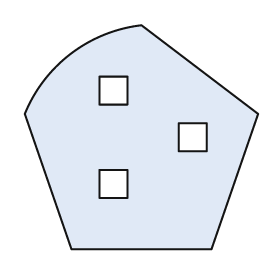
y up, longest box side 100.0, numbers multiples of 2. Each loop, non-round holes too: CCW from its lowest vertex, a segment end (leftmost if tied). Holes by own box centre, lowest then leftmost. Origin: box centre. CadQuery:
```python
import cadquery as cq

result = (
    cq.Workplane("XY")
    .moveTo(-30.0, -48.0)
    .lineTo(30.0, -48.0)
    .lineTo(50.0, 10.0)
    .lineTo(0.0, 48.0)
    .threePointArc((-30.0, 36.0), (-50.0, 10.0))
    .close()
    .moveTo(-18.0, -26.0)
    .lineTo(-6.0, -26.0)
    .lineTo(-6.0, -14.0)
    .lineTo(-18.0, -14.0)
    .close()
    .moveTo(16.0, -6.0)
    .lineTo(28.0, -6.0)
    .lineTo(28.0, 6.0)
    .lineTo(16.0, 6.0)
    .close()
    .moveTo(-18.0, 14.0)
    .lineTo(-6.0, 14.0)
    .lineTo(-6.0, 26.0)
    .lineTo(-18.0, 26.0)
    .close()
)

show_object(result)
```